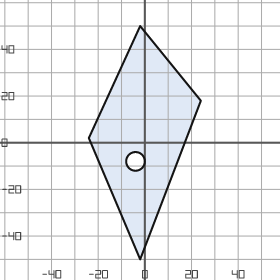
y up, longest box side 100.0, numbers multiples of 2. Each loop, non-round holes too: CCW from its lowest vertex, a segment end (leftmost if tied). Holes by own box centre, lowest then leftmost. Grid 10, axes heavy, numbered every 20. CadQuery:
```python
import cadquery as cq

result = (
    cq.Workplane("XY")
    .moveTo(-2.0, -50.0)
    .lineTo(24.0, 18.0)
    .lineTo(-2.0, 50.0)
    .lineTo(-24.0, 2.0)
    .close()
    .moveTo(-4.0, -8.0)
    .circle(4.0)
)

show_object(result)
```